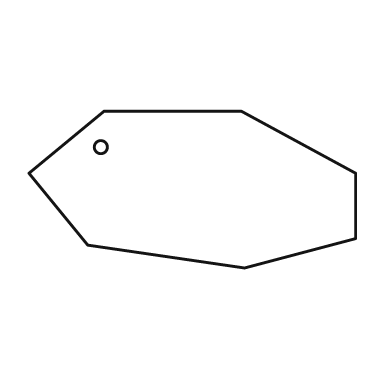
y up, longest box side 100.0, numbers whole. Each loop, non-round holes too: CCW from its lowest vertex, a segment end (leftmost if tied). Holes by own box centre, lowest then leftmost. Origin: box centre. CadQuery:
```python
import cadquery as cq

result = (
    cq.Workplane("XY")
    .moveTo(16.0, -24.0)
    .lineTo(50.0, -15.0)
    .lineTo(50.0, 5.0)
    .lineTo(15.0, 24.0)
    .lineTo(-27.0, 24.0)
    .lineTo(-50.0, 5.0)
    .lineTo(-32.0, -17.0)
    .close()
    .moveTo(-28.0, 13.0)
    .circle(2.0)
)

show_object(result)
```